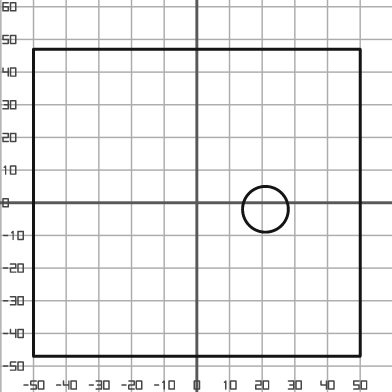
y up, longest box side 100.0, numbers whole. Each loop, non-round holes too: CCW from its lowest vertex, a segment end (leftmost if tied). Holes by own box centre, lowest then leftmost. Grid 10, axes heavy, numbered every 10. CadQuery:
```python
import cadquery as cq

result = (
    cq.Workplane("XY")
    .moveTo(-50.0, -47.0)
    .lineTo(50.0, -47.0)
    .lineTo(50.0, 47.0)
    .lineTo(-50.0, 47.0)
    .close()
    .moveTo(21.0, -2.0)
    .circle(7.0)
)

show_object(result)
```